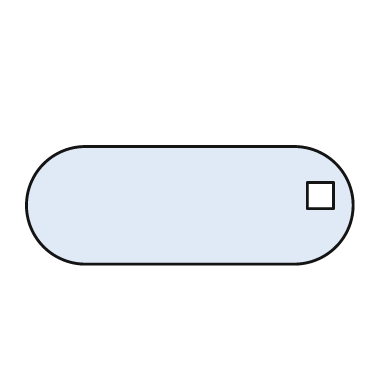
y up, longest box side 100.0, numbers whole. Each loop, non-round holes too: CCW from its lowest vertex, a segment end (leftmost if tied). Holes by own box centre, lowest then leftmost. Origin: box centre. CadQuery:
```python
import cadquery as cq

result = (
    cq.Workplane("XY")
    .moveTo(-32.0, -18.0)
    .lineTo(32.0, -18.0)
    .threePointArc((50.0, 0.0), (32.0, 18.0))
    .lineTo(-32.0, 18.0)
    .threePointArc((-50.0, 0.0), (-32.0, -18.0))
    .close()
    .moveTo(36.0, -1.0)
    .lineTo(44.0, -1.0)
    .lineTo(44.0, 7.0)
    .lineTo(36.0, 7.0)
    .close()
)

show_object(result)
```